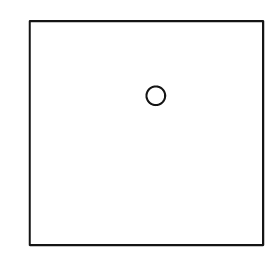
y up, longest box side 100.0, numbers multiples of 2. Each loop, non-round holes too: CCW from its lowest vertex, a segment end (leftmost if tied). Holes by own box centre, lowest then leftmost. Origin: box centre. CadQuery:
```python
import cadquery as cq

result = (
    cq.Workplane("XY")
    .moveTo(-50.0, -48.0)
    .lineTo(50.0, -48.0)
    .lineTo(50.0, 48.0)
    .lineTo(-50.0, 48.0)
    .close()
    .moveTo(4.0, 16.0)
    .circle(4.0)
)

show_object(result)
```